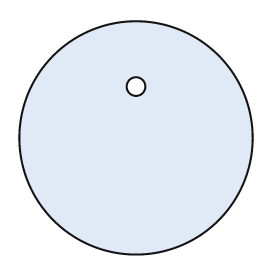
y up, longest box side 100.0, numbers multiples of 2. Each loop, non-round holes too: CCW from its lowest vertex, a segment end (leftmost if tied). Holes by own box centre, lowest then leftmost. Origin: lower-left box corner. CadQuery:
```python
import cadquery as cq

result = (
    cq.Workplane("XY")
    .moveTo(50.0, 50.0)
    .circle(50.0)
    .moveTo(50.0, 72.0)
    .circle(4.0)
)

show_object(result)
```